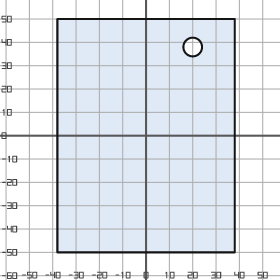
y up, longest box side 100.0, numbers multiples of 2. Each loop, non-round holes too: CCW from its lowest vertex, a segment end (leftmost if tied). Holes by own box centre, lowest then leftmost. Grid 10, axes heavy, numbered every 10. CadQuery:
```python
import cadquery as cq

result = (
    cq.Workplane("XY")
    .moveTo(-38.0, -50.0)
    .lineTo(38.0, -50.0)
    .lineTo(38.0, 50.0)
    .lineTo(-38.0, 50.0)
    .close()
    .moveTo(20.0, 38.0)
    .circle(4.0)
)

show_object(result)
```